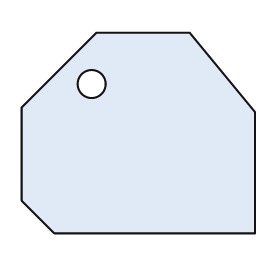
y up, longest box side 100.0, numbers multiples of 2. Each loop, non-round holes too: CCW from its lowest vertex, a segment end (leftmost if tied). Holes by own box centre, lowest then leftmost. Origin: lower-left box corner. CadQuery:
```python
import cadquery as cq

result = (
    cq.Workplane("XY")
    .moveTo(14.0, 0.0)
    .lineTo(100.0, 0.0)
    .lineTo(100.0, 52.0)
    .lineTo(72.0, 86.0)
    .lineTo(32.0, 86.0)
    .lineTo(0.0, 54.0)
    .lineTo(0.0, 14.0)
    .close()
    .moveTo(30.0, 64.0)
    .circle(6.0)
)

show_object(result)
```